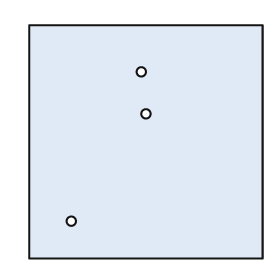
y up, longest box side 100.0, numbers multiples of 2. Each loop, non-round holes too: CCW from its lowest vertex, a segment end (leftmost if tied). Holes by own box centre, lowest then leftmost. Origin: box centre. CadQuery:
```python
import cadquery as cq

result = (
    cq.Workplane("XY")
    .moveTo(-50.0, -50.0)
    .lineTo(50.0, -50.0)
    .lineTo(50.0, 50.0)
    .lineTo(-50.0, 50.0)
    .close()
    .moveTo(-32.0, -34.0)
    .circle(2.0)
    .moveTo(0.0, 12.0)
    .circle(2.0)
    .moveTo(-2.0, 30.0)
    .circle(2.0)
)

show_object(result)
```